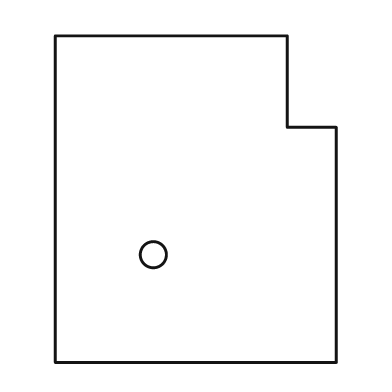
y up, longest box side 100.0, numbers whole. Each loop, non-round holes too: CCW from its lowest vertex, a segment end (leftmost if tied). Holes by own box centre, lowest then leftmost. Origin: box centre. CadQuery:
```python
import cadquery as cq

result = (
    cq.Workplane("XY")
    .moveTo(-43.0, -50.0)
    .lineTo(43.0, -50.0)
    .lineTo(43.0, 22.0)
    .lineTo(28.0, 22.0)
    .lineTo(28.0, 50.0)
    .lineTo(-43.0, 50.0)
    .close()
    .moveTo(-13.0, -17.0)
    .circle(4.0)
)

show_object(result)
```